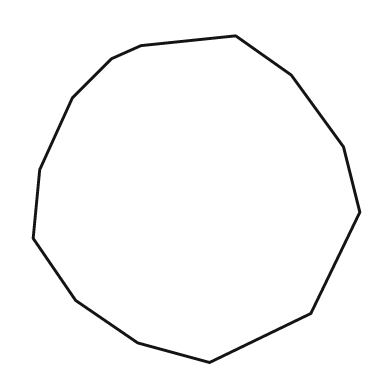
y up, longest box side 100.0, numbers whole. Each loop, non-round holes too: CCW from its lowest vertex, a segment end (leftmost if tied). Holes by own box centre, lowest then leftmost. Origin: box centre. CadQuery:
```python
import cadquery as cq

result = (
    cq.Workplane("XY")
    .moveTo(4.0, -50.0)
    .lineTo(35.0, -35.0)
    .lineTo(50.0, -4.0)
    .lineTo(45.0, 16.0)
    .lineTo(29.0, 38.0)
    .lineTo(12.0, 50.0)
    .lineTo(-17.0, 47.0)
    .lineTo(-26.0, 43.0)
    .lineTo(-38.0, 31.0)
    .lineTo(-48.0, 9.0)
    .lineTo(-50.0, -12.0)
    .lineTo(-37.0, -31.0)
    .lineTo(-18.0, -44.0)
    .close()
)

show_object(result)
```